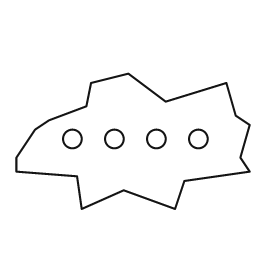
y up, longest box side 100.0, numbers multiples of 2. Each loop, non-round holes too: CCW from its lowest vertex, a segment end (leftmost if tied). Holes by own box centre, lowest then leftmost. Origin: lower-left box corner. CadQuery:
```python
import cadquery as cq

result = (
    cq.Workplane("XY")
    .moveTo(28.0, 0.0)
    .lineTo(46.0, 8.0)
    .lineTo(68.0, 0.0)
    .lineTo(72.0, 12.0)
    .lineTo(100.0, 16.0)
    .lineTo(96.0, 22.0)
    .lineTo(100.0, 36.0)
    .lineTo(94.0, 40.0)
    .lineTo(90.0, 54.0)
    .lineTo(64.0, 46.0)
    .lineTo(48.0, 58.0)
    .lineTo(32.0, 54.0)
    .lineTo(30.0, 44.0)
    .lineTo(14.0, 38.0)
    .lineTo(8.0, 34.0)
    .lineTo(0.0, 22.0)
    .lineTo(0.0, 16.0)
    .lineTo(26.0, 14.0)
    .close()
    .moveTo(24.0, 30.0)
    .circle(4.0)
    .moveTo(42.0, 30.0)
    .circle(4.0)
    .moveTo(60.0, 30.0)
    .circle(4.0)
    .moveTo(78.0, 30.0)
    .circle(4.0)
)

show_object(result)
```